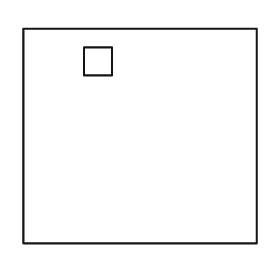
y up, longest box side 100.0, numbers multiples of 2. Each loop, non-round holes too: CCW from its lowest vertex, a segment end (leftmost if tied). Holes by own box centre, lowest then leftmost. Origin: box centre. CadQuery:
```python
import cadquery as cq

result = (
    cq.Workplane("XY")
    .moveTo(-50.0, -46.0)
    .lineTo(50.0, -46.0)
    .lineTo(50.0, 46.0)
    .lineTo(-50.0, 46.0)
    .close()
    .moveTo(-24.0, 26.0)
    .lineTo(-12.0, 26.0)
    .lineTo(-12.0, 38.0)
    .lineTo(-24.0, 38.0)
    .close()
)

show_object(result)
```